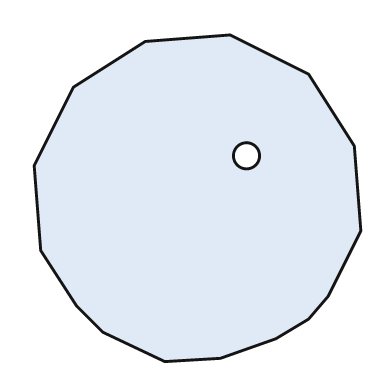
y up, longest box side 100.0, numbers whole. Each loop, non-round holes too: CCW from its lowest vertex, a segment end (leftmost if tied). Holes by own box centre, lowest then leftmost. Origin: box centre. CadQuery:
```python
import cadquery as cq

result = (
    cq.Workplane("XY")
    .moveTo(-10.0, -50.0)
    .lineTo(7.0, -49.0)
    .lineTo(24.0, -43.0)
    .lineTo(34.0, -37.0)
    .lineTo(40.0, -30.0)
    .lineTo(50.0, -10.0)
    .lineTo(48.0, 16.0)
    .lineTo(34.0, 38.0)
    .lineTo(10.0, 50.0)
    .lineTo(-16.0, 48.0)
    .lineTo(-38.0, 34.0)
    .lineTo(-50.0, 10.0)
    .lineTo(-48.0, -16.0)
    .lineTo(-37.0, -33.0)
    .lineTo(-29.0, -41.0)
    .close()
    .moveTo(15.0, 13.0)
    .circle(4.0)
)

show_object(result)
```